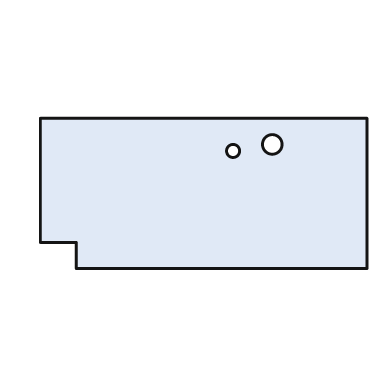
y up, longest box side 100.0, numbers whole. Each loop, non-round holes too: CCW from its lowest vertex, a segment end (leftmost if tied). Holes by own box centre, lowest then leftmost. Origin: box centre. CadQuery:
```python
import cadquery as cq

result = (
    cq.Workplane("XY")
    .moveTo(-39.0, -23.0)
    .lineTo(50.0, -23.0)
    .lineTo(50.0, 23.0)
    .lineTo(-50.0, 23.0)
    .lineTo(-50.0, -15.0)
    .lineTo(-39.0, -15.0)
    .close()
    .moveTo(9.0, 13.0)
    .circle(2.0)
    .moveTo(21.0, 15.0)
    .circle(3.0)
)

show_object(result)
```